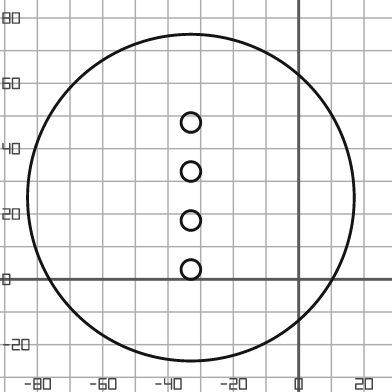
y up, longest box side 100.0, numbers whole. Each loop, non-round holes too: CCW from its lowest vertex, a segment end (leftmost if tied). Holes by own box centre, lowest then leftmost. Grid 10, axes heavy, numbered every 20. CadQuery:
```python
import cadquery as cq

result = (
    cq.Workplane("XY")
    .moveTo(-33.0, 25.0)
    .circle(50.0)
    .moveTo(-33.0, 3.0)
    .circle(3.0)
    .moveTo(-33.0, 18.0)
    .circle(3.0)
    .moveTo(-33.0, 33.0)
    .circle(3.0)
    .moveTo(-33.0, 48.0)
    .circle(3.0)
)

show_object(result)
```